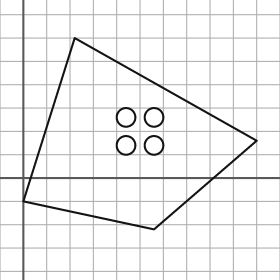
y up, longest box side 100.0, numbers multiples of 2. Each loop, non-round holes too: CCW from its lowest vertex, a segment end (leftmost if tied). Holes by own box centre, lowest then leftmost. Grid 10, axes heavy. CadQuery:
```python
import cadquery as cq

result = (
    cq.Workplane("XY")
    .moveTo(56.0, -22.0)
    .lineTo(100.0, 16.0)
    .lineTo(22.0, 60.0)
    .lineTo(0.0, -10.0)
    .close()
    .moveTo(44.0, 14.0)
    .circle(4.0)
    .moveTo(56.0, 14.0)
    .circle(4.0)
    .moveTo(44.0, 26.0)
    .circle(4.0)
    .moveTo(56.0, 26.0)
    .circle(4.0)
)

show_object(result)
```